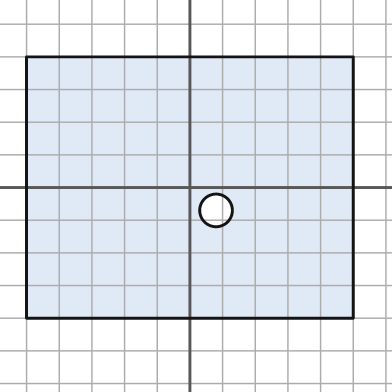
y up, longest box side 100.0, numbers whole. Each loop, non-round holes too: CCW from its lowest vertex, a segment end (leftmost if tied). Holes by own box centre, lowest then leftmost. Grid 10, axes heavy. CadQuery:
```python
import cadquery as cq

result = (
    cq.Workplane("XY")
    .moveTo(-50.0, -40.0)
    .lineTo(50.0, -40.0)
    .lineTo(50.0, 40.0)
    .lineTo(-50.0, 40.0)
    .close()
    .moveTo(8.0, -7.0)
    .circle(5.0)
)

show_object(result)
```